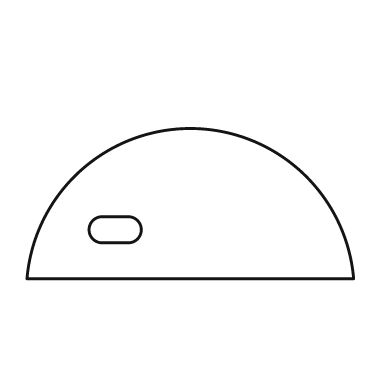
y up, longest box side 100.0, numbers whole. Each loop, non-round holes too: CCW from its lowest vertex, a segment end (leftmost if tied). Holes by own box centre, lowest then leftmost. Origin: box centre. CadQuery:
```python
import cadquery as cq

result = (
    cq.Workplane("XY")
    .moveTo(-50.0, -23.0)
    .lineTo(50.0, -23.0)
    .threePointArc((0.0, 23.0), (-50.0, -23.0))
    .close()
    .moveTo(-27.0, -12.0)
    .lineTo(-19.0, -12.0)
    .threePointArc((-15.0, -8.0), (-19.0, -4.0))
    .lineTo(-27.0, -4.0)
    .threePointArc((-31.0, -8.0), (-27.0, -12.0))
    .close()
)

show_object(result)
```